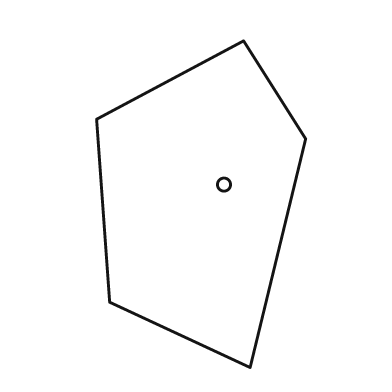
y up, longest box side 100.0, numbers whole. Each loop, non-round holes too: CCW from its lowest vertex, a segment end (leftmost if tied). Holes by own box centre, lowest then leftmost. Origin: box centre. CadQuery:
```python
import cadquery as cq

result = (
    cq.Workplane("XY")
    .moveTo(15.0, -50.0)
    .lineTo(32.0, 20.0)
    .lineTo(13.0, 50.0)
    .lineTo(-32.0, 26.0)
    .lineTo(-28.0, -30.0)
    .close()
    .moveTo(7.0, 6.0)
    .circle(2.0)
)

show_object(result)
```